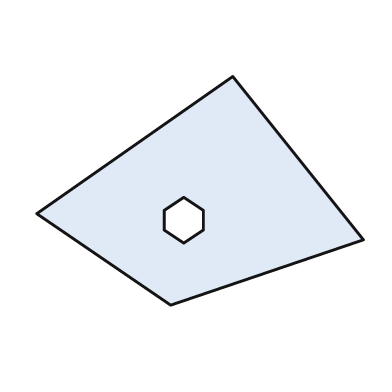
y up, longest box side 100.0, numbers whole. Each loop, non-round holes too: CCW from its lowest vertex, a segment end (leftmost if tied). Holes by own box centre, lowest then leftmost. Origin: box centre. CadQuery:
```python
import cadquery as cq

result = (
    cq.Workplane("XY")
    .moveTo(-9.0, -35.0)
    .lineTo(50.0, -15.0)
    .lineTo(10.0, 35.0)
    .lineTo(-50.0, -7.0)
    .close()
    .moveTo(-5.0, -16.0)
    .lineTo(1.0, -12.0)
    .lineTo(1.0, -6.0)
    .lineTo(-5.0, -2.0)
    .lineTo(-11.0, -6.0)
    .lineTo(-11.0, -12.0)
    .close()
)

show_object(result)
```